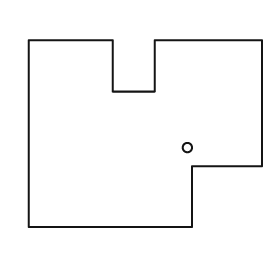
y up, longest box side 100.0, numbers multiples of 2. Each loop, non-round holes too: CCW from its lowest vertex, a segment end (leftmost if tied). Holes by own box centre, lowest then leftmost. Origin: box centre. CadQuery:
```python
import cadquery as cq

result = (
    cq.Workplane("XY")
    .moveTo(-50.0, -40.0)
    .lineTo(20.0, -40.0)
    .lineTo(20.0, -14.0)
    .lineTo(50.0, -14.0)
    .lineTo(50.0, 40.0)
    .lineTo(4.0, 40.0)
    .lineTo(4.0, 18.0)
    .lineTo(-14.0, 18.0)
    .lineTo(-14.0, 40.0)
    .lineTo(-50.0, 40.0)
    .close()
    .moveTo(18.0, -6.0)
    .circle(2.0)
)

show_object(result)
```